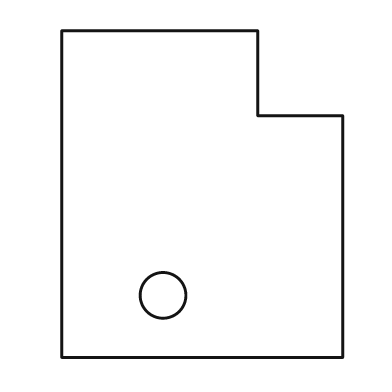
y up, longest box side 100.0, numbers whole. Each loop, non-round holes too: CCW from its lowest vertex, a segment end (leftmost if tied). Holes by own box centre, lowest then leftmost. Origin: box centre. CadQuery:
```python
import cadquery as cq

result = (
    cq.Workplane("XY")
    .moveTo(-43.0, -50.0)
    .lineTo(43.0, -50.0)
    .lineTo(43.0, 24.0)
    .lineTo(17.0, 24.0)
    .lineTo(17.0, 50.0)
    .lineTo(-43.0, 50.0)
    .close()
    .moveTo(-12.0, -31.0)
    .circle(7.0)
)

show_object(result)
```